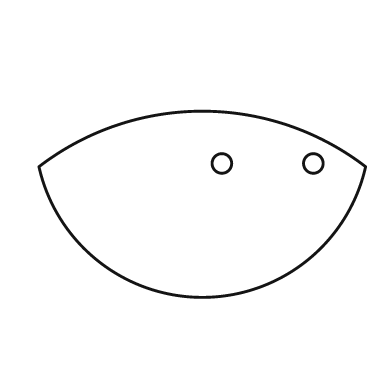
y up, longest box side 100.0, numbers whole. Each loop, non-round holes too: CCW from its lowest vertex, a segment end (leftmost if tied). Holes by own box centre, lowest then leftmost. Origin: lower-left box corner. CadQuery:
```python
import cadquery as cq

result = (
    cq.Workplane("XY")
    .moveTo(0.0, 40.0)
    .threePointArc((50.0, 0.0), (100.0, 40.0))
    .threePointArc((50.0, 57.0), (0.0, 40.0))
    .close()
    .moveTo(56.0, 41.0)
    .circle(3.0)
    .moveTo(84.0, 41.0)
    .circle(3.0)
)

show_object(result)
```